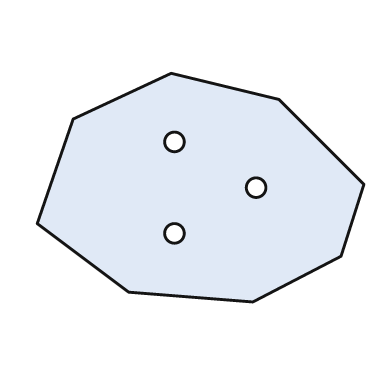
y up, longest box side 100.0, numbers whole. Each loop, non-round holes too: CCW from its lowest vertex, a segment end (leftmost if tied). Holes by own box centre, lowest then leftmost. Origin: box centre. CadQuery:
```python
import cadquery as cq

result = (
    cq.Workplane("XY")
    .moveTo(16.0, -35.0)
    .lineTo(43.0, -21.0)
    .lineTo(50.0, 1.0)
    .lineTo(24.0, 27.0)
    .lineTo(-9.0, 35.0)
    .lineTo(-39.0, 21.0)
    .lineTo(-50.0, -11.0)
    .lineTo(-22.0, -32.0)
    .close()
    .moveTo(-8.0, -14.0)
    .circle(3.0)
    .moveTo(17.0, 0.0)
    .circle(3.0)
    .moveTo(-8.0, 14.0)
    .circle(3.0)
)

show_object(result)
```